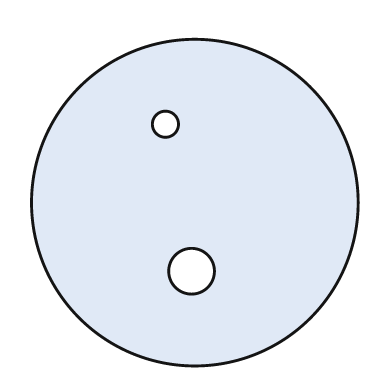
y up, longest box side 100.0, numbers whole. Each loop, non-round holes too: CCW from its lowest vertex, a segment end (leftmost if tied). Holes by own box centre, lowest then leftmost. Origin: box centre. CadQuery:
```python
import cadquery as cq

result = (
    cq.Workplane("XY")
    .moveTo(0.0, 0.0)
    .circle(50.0)
    .moveTo(-1.0, -21.0)
    .circle(7.0)
    .moveTo(-9.0, 24.0)
    .circle(4.0)
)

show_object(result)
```